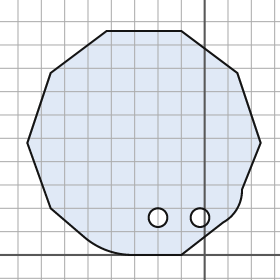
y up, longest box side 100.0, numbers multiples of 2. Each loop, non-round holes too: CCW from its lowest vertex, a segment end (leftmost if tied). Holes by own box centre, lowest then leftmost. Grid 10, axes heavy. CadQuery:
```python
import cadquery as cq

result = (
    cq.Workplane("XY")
    .moveTo(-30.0, 0.0)
    .lineTo(-10.0, 0.0)
    .lineTo(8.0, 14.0)
    .threePointArc((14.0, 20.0), (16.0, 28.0))
    .lineTo(24.0, 48.0)
    .lineTo(14.0, 78.0)
    .lineTo(-10.0, 96.0)
    .lineTo(-42.0, 96.0)
    .lineTo(-66.0, 78.0)
    .lineTo(-76.0, 48.0)
    .lineTo(-66.0, 20.0)
    .lineTo(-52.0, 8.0)
    .threePointArc((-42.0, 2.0), (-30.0, 0.0))
    .close()
    .moveTo(-20.0, 16.0)
    .circle(4.0)
    .moveTo(-2.0, 16.0)
    .circle(4.0)
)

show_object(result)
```